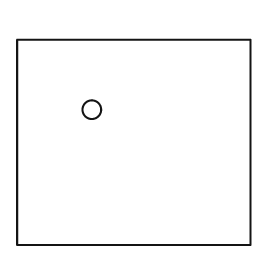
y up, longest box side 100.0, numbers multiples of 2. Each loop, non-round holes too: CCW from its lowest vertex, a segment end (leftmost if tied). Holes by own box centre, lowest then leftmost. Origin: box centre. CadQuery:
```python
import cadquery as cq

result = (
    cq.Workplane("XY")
    .moveTo(-50.0, -44.0)
    .lineTo(50.0, -44.0)
    .lineTo(50.0, 44.0)
    .lineTo(-50.0, 44.0)
    .close()
    .moveTo(-18.0, 14.0)
    .circle(4.0)
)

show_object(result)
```